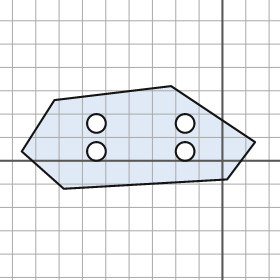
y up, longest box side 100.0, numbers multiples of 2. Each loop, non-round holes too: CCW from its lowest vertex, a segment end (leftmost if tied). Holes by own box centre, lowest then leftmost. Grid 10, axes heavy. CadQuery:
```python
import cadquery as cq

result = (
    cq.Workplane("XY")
    .moveTo(-68.0, -12.0)
    .lineTo(2.0, -8.0)
    .lineTo(14.0, 8.0)
    .lineTo(-22.0, 32.0)
    .lineTo(-72.0, 26.0)
    .lineTo(-86.0, 4.0)
    .close()
    .moveTo(-54.0, 4.0)
    .circle(4.0)
    .moveTo(-16.0, 4.0)
    .circle(4.0)
    .moveTo(-54.0, 16.0)
    .circle(4.0)
    .moveTo(-16.0, 16.0)
    .circle(4.0)
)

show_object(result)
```